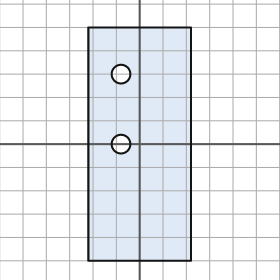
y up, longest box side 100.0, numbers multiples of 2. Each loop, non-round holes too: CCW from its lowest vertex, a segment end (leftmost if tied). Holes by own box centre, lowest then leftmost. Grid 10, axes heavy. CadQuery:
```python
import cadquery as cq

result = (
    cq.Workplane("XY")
    .moveTo(-22.0, -50.0)
    .lineTo(22.0, -50.0)
    .lineTo(22.0, 50.0)
    .lineTo(-22.0, 50.0)
    .close()
    .moveTo(-8.0, 0.0)
    .circle(4.0)
    .moveTo(-8.0, 30.0)
    .circle(4.0)
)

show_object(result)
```